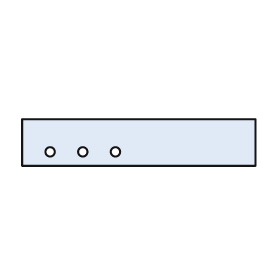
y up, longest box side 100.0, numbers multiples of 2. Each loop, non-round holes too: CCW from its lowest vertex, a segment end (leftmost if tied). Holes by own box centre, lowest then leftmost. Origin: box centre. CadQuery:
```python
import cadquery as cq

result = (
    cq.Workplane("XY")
    .moveTo(-50.0, -10.0)
    .lineTo(50.0, -10.0)
    .lineTo(50.0, 10.0)
    .lineTo(-50.0, 10.0)
    .close()
    .moveTo(-38.0, -4.0)
    .circle(2.0)
    .moveTo(-24.0, -4.0)
    .circle(2.0)
    .moveTo(-10.0, -4.0)
    .circle(2.0)
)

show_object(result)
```